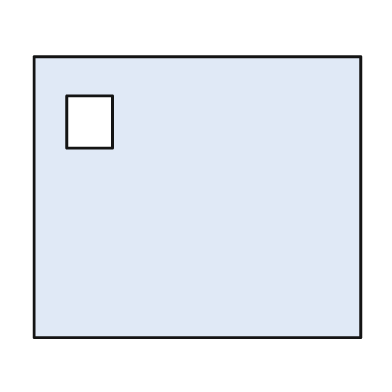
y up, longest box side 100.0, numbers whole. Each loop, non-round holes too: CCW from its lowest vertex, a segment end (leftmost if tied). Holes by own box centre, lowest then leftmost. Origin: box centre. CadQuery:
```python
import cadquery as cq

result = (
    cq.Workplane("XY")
    .moveTo(-50.0, -43.0)
    .lineTo(50.0, -43.0)
    .lineTo(50.0, 43.0)
    .lineTo(-50.0, 43.0)
    .close()
    .moveTo(-40.0, 15.0)
    .lineTo(-26.0, 15.0)
    .lineTo(-26.0, 31.0)
    .lineTo(-40.0, 31.0)
    .close()
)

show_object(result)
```